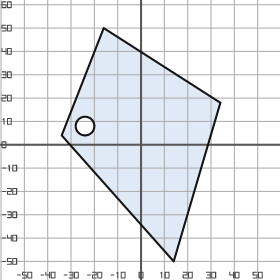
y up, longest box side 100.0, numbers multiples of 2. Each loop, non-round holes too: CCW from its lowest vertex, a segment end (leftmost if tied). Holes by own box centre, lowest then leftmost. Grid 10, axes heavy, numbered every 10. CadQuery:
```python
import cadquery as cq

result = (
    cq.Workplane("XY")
    .moveTo(14.0, -50.0)
    .lineTo(34.0, 18.0)
    .lineTo(-16.0, 50.0)
    .lineTo(-34.0, 4.0)
    .close()
    .moveTo(-24.0, 8.0)
    .circle(4.0)
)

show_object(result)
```